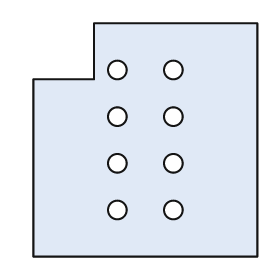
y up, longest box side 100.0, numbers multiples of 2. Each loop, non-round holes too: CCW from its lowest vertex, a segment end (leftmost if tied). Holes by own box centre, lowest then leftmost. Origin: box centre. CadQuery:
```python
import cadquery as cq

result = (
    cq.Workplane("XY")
    .moveTo(-48.0, -50.0)
    .lineTo(48.0, -50.0)
    .lineTo(48.0, 50.0)
    .lineTo(-22.0, 50.0)
    .lineTo(-22.0, 26.0)
    .lineTo(-48.0, 26.0)
    .close()
    .moveTo(-12.0, -30.0)
    .circle(4.0)
    .moveTo(12.0, -30.0)
    .circle(4.0)
    .moveTo(-12.0, -10.0)
    .circle(4.0)
    .moveTo(12.0, -10.0)
    .circle(4.0)
    .moveTo(-12.0, 10.0)
    .circle(4.0)
    .moveTo(12.0, 10.0)
    .circle(4.0)
    .moveTo(-12.0, 30.0)
    .circle(4.0)
    .moveTo(12.0, 30.0)
    .circle(4.0)
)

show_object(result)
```